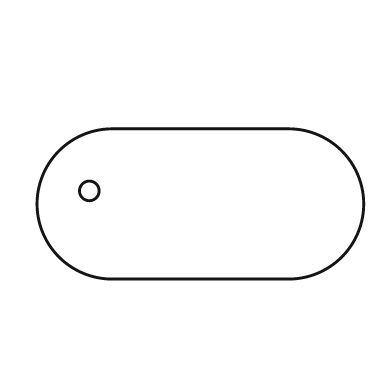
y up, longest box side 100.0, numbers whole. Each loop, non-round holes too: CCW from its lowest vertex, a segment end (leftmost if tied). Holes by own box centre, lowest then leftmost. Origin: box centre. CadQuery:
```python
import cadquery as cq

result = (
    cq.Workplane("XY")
    .moveTo(-27.0, -23.0)
    .lineTo(27.0, -23.0)
    .threePointArc((50.0, 0.0), (27.0, 23.0))
    .lineTo(-27.0, 23.0)
    .threePointArc((-50.0, 0.0), (-27.0, -23.0))
    .close()
    .moveTo(-34.0, 4.0)
    .circle(3.0)
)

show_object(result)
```